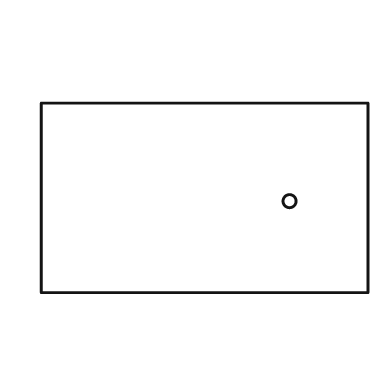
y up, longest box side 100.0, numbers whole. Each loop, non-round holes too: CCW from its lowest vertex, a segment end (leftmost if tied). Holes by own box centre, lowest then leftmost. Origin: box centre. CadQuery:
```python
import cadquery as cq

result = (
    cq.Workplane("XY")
    .moveTo(-50.0, -29.0)
    .lineTo(50.0, -29.0)
    .lineTo(50.0, 29.0)
    .lineTo(-50.0, 29.0)
    .close()
    .moveTo(26.0, -1.0)
    .circle(2.0)
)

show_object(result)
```